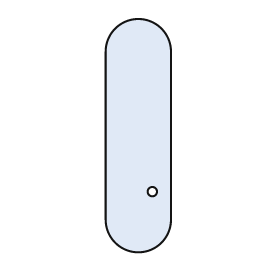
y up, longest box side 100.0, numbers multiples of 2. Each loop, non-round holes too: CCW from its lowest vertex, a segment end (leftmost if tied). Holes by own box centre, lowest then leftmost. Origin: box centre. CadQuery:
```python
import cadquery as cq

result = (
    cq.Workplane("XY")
    .moveTo(-14.0, -36.0)
    .threePointArc((0.0, -50.0), (14.0, -36.0))
    .lineTo(14.0, 36.0)
    .threePointArc((0.0, 50.0), (-14.0, 36.0))
    .close()
    .moveTo(6.0, -24.0)
    .circle(2.0)
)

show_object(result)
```